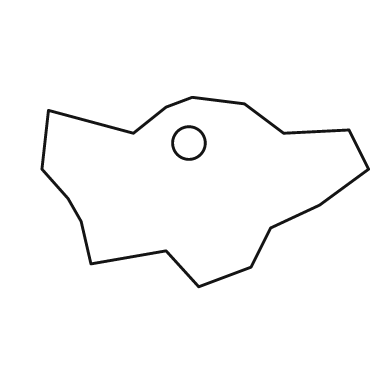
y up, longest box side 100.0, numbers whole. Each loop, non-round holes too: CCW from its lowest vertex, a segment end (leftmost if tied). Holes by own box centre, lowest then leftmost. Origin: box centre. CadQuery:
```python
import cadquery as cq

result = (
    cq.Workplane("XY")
    .moveTo(-2.0, -29.0)
    .lineTo(14.0, -23.0)
    .lineTo(20.0, -11.0)
    .lineTo(35.0, -4.0)
    .lineTo(50.0, 7.0)
    .lineTo(44.0, 19.0)
    .lineTo(24.0, 18.0)
    .lineTo(12.0, 27.0)
    .lineTo(-4.0, 29.0)
    .lineTo(-12.0, 26.0)
    .lineTo(-22.0, 18.0)
    .lineTo(-48.0, 25.0)
    .lineTo(-50.0, 7.0)
    .lineTo(-42.0, -2.0)
    .lineTo(-38.0, -9.0)
    .lineTo(-35.0, -22.0)
    .lineTo(-12.0, -18.0)
    .close()
    .moveTo(-5.0, 15.0)
    .circle(5.0)
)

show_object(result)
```